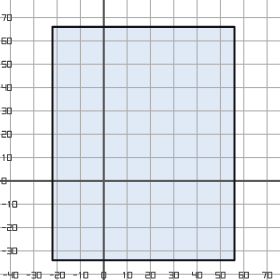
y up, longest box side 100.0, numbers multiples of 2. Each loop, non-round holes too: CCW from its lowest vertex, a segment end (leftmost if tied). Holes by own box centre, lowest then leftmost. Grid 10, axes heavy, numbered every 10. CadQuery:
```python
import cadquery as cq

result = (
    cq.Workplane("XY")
    .moveTo(-22.0, -34.0)
    .lineTo(56.0, -34.0)
    .lineTo(56.0, 66.0)
    .lineTo(-22.0, 66.0)
    .close()
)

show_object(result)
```